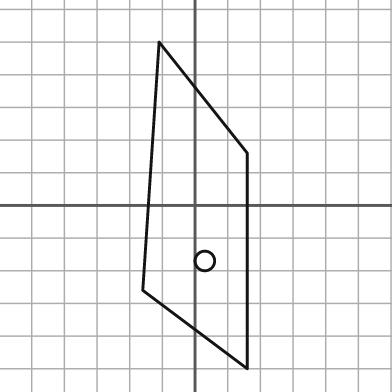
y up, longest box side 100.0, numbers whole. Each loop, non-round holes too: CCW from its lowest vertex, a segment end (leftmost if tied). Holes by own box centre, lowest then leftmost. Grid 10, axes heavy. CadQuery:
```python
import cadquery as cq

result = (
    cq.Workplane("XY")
    .moveTo(16.0, -50.0)
    .lineTo(16.0, 16.0)
    .lineTo(-11.0, 50.0)
    .lineTo(-16.0, -26.0)
    .close()
    .moveTo(3.0, -17.0)
    .circle(3.0)
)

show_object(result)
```